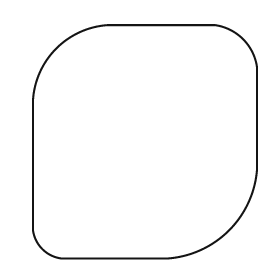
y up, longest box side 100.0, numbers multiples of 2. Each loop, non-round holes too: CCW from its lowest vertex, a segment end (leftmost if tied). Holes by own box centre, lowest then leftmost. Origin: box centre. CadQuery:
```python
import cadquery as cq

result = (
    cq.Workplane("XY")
    .moveTo(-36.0, -50.0)
    .lineTo(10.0, -50.0)
    .threePointArc((36.0, -38.0), (48.0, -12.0))
    .lineTo(48.0, 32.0)
    .threePointArc((42.0, 44.0), (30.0, 50.0))
    .lineTo(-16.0, 50.0)
    .threePointArc((-38.0, 40.0), (-48.0, 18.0))
    .lineTo(-48.0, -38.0)
    .threePointArc((-44.0, -46.0), (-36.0, -50.0))
    .close()
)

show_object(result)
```